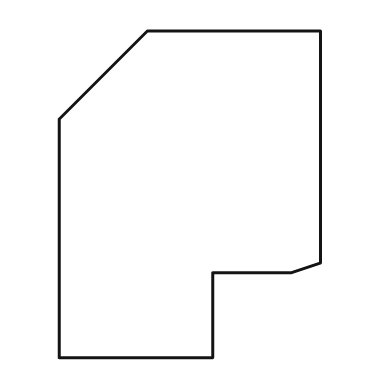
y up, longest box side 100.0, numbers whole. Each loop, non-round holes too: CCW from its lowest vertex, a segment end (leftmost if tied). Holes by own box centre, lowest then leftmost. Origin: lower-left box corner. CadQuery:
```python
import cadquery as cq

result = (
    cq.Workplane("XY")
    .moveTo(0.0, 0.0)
    .lineTo(47.0, 0.0)
    .lineTo(47.0, 26.0)
    .lineTo(71.0, 26.0)
    .lineTo(80.0, 29.0)
    .lineTo(80.0, 100.0)
    .lineTo(27.0, 100.0)
    .lineTo(0.0, 73.0)
    .close()
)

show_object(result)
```